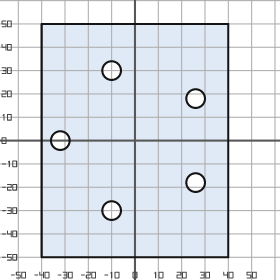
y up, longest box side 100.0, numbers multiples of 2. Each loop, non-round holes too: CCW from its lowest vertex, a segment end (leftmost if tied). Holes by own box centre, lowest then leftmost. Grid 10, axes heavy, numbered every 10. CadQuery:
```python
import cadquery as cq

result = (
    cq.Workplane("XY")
    .moveTo(-40.0, -50.0)
    .lineTo(40.0, -50.0)
    .lineTo(40.0, 50.0)
    .lineTo(-40.0, 50.0)
    .close()
    .moveTo(-10.0, -30.0)
    .circle(4.0)
    .moveTo(26.0, -18.0)
    .circle(4.0)
    .moveTo(-32.0, 0.0)
    .circle(4.0)
    .moveTo(26.0, 18.0)
    .circle(4.0)
    .moveTo(-10.0, 30.0)
    .circle(4.0)
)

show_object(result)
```